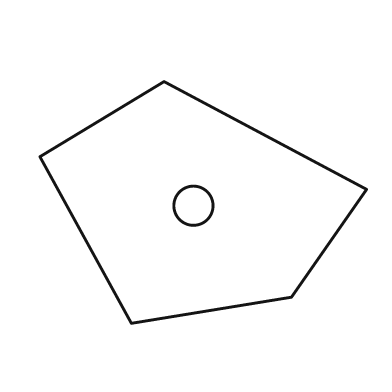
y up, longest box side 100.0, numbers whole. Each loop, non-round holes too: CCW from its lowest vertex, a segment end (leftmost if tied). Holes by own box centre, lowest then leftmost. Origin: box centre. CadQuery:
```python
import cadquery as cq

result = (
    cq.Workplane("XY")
    .moveTo(-22.0, -37.0)
    .lineTo(27.0, -29.0)
    .lineTo(50.0, 4.0)
    .lineTo(-12.0, 37.0)
    .lineTo(-50.0, 14.0)
    .close()
    .moveTo(-3.0, -1.0)
    .circle(6.0)
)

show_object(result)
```